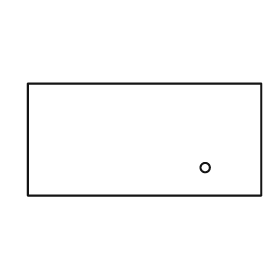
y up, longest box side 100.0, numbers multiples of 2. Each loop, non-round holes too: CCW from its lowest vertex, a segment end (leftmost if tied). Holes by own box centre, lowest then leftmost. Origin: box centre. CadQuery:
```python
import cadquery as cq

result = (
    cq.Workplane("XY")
    .moveTo(-50.0, -24.0)
    .lineTo(50.0, -24.0)
    .lineTo(50.0, 24.0)
    .lineTo(-50.0, 24.0)
    .close()
    .moveTo(26.0, -12.0)
    .circle(2.0)
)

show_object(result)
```